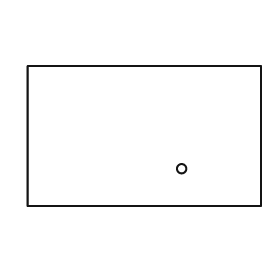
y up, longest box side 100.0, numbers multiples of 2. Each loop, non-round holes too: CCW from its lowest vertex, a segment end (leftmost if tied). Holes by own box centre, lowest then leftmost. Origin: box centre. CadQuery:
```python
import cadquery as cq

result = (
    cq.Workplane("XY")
    .moveTo(-50.0, -30.0)
    .lineTo(50.0, -30.0)
    .lineTo(50.0, 30.0)
    .lineTo(-50.0, 30.0)
    .close()
    .moveTo(16.0, -14.0)
    .circle(2.0)
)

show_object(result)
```